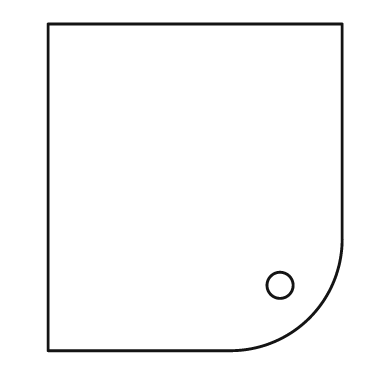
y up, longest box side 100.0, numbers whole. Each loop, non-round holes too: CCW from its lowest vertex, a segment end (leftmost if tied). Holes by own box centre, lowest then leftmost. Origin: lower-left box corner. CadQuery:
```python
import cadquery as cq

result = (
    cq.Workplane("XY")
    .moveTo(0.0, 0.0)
    .lineTo(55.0, 0.0)
    .threePointArc((80.0, 10.0), (90.0, 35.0))
    .lineTo(90.0, 100.0)
    .lineTo(0.0, 100.0)
    .close()
    .moveTo(71.0, 20.0)
    .circle(4.0)
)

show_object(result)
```